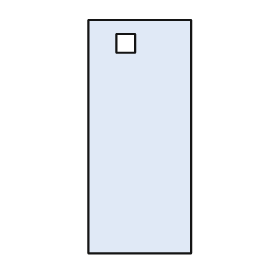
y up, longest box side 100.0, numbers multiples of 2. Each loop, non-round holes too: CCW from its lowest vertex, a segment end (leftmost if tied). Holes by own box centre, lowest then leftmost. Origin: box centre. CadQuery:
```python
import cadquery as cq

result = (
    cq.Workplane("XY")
    .moveTo(-22.0, -50.0)
    .lineTo(22.0, -50.0)
    .lineTo(22.0, 50.0)
    .lineTo(-22.0, 50.0)
    .close()
    .moveTo(-10.0, 36.0)
    .lineTo(-2.0, 36.0)
    .lineTo(-2.0, 44.0)
    .lineTo(-10.0, 44.0)
    .close()
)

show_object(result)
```